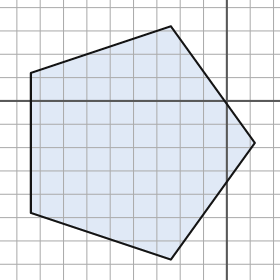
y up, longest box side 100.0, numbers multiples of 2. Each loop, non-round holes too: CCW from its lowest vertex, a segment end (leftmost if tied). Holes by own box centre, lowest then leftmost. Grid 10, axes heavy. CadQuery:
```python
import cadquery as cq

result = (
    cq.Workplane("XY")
    .moveTo(-24.0, -68.0)
    .lineTo(12.0, -18.0)
    .lineTo(-24.0, 32.0)
    .lineTo(-84.0, 12.0)
    .lineTo(-84.0, -48.0)
    .close()
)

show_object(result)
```